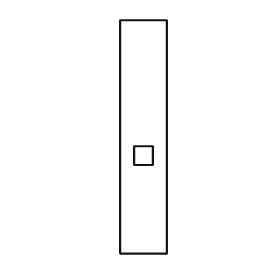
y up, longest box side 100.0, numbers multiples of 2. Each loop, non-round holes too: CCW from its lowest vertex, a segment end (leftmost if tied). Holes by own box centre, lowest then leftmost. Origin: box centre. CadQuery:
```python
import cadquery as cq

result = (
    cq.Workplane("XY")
    .moveTo(-10.0, -50.0)
    .lineTo(10.0, -50.0)
    .lineTo(10.0, 50.0)
    .lineTo(-10.0, 50.0)
    .close()
    .moveTo(-4.0, -12.0)
    .lineTo(4.0, -12.0)
    .lineTo(4.0, -4.0)
    .lineTo(-4.0, -4.0)
    .close()
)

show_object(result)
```